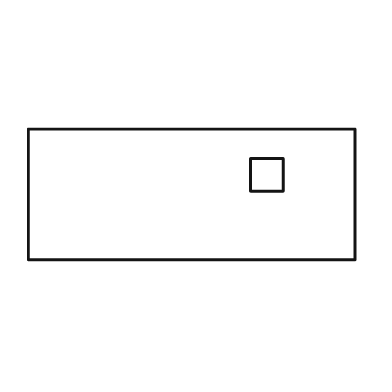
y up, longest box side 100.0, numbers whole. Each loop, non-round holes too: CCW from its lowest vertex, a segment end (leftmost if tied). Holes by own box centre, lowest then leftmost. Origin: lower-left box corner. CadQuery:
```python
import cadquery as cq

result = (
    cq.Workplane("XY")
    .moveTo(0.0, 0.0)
    .lineTo(100.0, 0.0)
    .lineTo(100.0, 40.0)
    .lineTo(0.0, 40.0)
    .close()
    .moveTo(68.0, 21.0)
    .lineTo(78.0, 21.0)
    .lineTo(78.0, 31.0)
    .lineTo(68.0, 31.0)
    .close()
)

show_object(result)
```